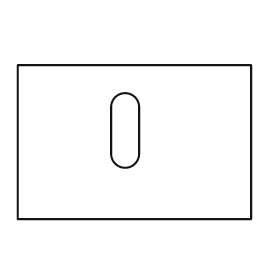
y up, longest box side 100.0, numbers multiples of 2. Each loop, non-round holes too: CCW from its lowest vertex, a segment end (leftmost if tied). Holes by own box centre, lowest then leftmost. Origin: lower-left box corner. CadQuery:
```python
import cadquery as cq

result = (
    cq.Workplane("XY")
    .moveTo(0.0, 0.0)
    .lineTo(100.0, 0.0)
    .lineTo(100.0, 66.0)
    .lineTo(0.0, 66.0)
    .close()
    .moveTo(40.0, 28.0)
    .threePointArc((46.0, 22.0), (52.0, 28.0))
    .lineTo(52.0, 48.0)
    .threePointArc((46.0, 54.0), (40.0, 48.0))
    .close()
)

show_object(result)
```